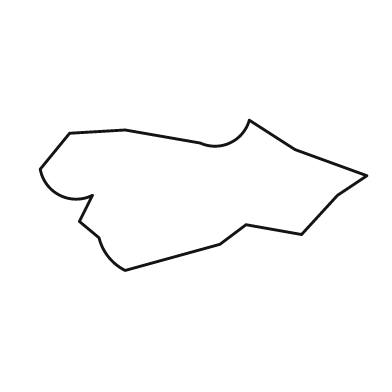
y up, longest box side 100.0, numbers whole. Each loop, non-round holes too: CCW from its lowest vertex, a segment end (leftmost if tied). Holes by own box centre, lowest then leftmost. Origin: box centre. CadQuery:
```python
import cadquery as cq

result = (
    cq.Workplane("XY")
    .moveTo(-24.0, -23.0)
    .lineTo(5.0, -15.0)
    .lineTo(13.0, -9.0)
    .lineTo(30.0, -12.0)
    .lineTo(41.0, 0.0)
    .lineTo(50.0, 6.0)
    .lineTo(28.0, 14.0)
    .lineTo(14.0, 23.0)
    .threePointArc((8.0, 16.0), (-1.0, 16.0))
    .lineTo(-24.0, 20.0)
    .lineTo(-41.0, 19.0)
    .lineTo(-50.0, 8.0)
    .threePointArc((-44.0, 0.0), (-34.0, 0.0))
    .lineTo(-38.0, -8.0)
    .lineTo(-32.0, -13.0)
    .threePointArc((-29.0, -19.0), (-24.0, -23.0))
    .close()
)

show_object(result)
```